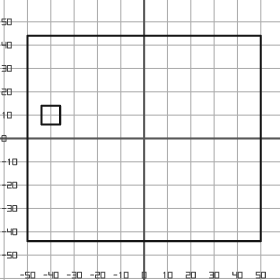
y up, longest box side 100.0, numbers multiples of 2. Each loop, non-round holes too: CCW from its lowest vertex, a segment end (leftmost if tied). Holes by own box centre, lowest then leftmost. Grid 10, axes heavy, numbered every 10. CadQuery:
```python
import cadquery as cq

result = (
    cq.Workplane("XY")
    .moveTo(-50.0, -44.0)
    .lineTo(50.0, -44.0)
    .lineTo(50.0, 44.0)
    .lineTo(-50.0, 44.0)
    .close()
    .moveTo(-44.0, 6.0)
    .lineTo(-36.0, 6.0)
    .lineTo(-36.0, 14.0)
    .lineTo(-44.0, 14.0)
    .close()
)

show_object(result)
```